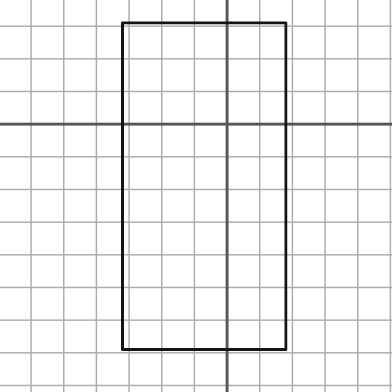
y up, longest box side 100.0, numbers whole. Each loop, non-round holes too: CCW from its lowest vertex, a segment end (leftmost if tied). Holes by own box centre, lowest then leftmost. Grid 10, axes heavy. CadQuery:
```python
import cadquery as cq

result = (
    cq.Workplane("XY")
    .moveTo(-32.0, -69.0)
    .lineTo(18.0, -69.0)
    .lineTo(18.0, 31.0)
    .lineTo(-32.0, 31.0)
    .close()
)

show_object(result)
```